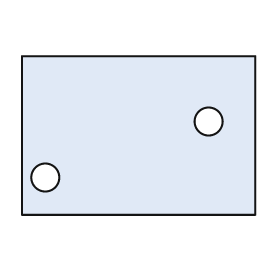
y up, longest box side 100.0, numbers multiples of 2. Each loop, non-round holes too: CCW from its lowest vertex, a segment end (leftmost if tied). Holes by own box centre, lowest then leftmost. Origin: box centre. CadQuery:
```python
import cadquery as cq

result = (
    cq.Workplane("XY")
    .moveTo(-50.0, -34.0)
    .lineTo(50.0, -34.0)
    .lineTo(50.0, 34.0)
    .lineTo(-50.0, 34.0)
    .close()
    .moveTo(-40.0, -18.0)
    .circle(6.0)
    .moveTo(30.0, 6.0)
    .circle(6.0)
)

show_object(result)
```